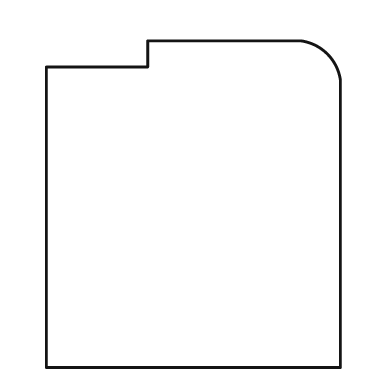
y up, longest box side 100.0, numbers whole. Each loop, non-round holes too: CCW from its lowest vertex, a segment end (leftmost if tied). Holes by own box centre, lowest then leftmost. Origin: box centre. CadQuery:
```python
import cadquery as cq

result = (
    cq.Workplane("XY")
    .moveTo(-45.0, -50.0)
    .lineTo(45.0, -50.0)
    .lineTo(45.0, 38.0)
    .threePointArc((41.0, 46.0), (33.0, 50.0))
    .lineTo(-14.0, 50.0)
    .lineTo(-14.0, 42.0)
    .lineTo(-45.0, 42.0)
    .close()
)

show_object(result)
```